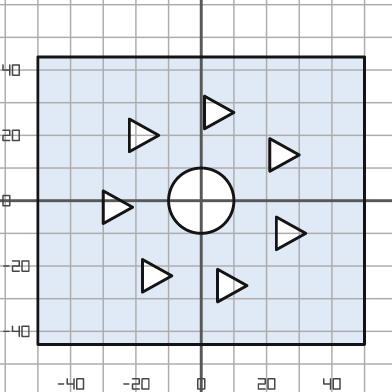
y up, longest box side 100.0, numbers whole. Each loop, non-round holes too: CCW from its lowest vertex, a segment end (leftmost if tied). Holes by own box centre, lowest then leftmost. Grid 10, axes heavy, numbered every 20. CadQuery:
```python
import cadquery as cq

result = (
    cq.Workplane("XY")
    .moveTo(-50.0, -44.0)
    .lineTo(50.0, -44.0)
    .lineTo(50.0, 44.0)
    .lineTo(-50.0, 44.0)
    .close()
    .moveTo(5.0, -31.0)
    .lineTo(14.0, -26.0)
    .lineTo(5.0, -21.0)
    .close()
    .moveTo(-18.0, -28.0)
    .lineTo(-9.0, -23.0)
    .lineTo(-18.0, -18.0)
    .close()
    .moveTo(23.0, -15.0)
    .lineTo(32.0, -10.0)
    .lineTo(23.0, -5.0)
    .close()
    .moveTo(-30.0, -7.0)
    .lineTo(-21.0, -2.0)
    .lineTo(-30.0, 3.0)
    .close()
    .moveTo(0.0, 0.0)
    .circle(10.0)
    .moveTo(21.0, 9.0)
    .lineTo(30.0, 14.0)
    .lineTo(21.0, 19.0)
    .close()
    .moveTo(-22.0, 15.0)
    .lineTo(-13.0, 20.0)
    .lineTo(-22.0, 25.0)
    .close()
    .moveTo(1.0, 22.0)
    .lineTo(10.0, 27.0)
    .lineTo(1.0, 32.0)
    .close()
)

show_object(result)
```